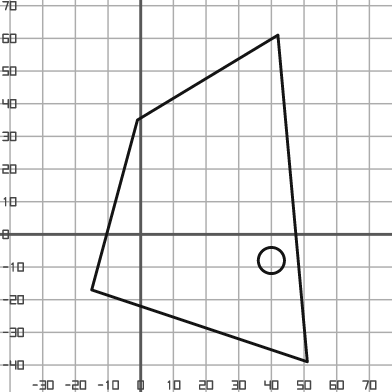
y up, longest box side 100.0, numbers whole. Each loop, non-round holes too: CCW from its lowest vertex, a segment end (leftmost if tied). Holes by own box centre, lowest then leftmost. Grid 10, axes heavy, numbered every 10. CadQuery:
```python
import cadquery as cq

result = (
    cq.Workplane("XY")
    .moveTo(51.0, -39.0)
    .lineTo(42.0, 61.0)
    .lineTo(-1.0, 35.0)
    .lineTo(-15.0, -17.0)
    .close()
    .moveTo(40.0, -8.0)
    .circle(4.0)
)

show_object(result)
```